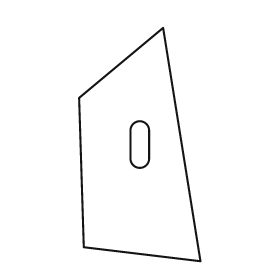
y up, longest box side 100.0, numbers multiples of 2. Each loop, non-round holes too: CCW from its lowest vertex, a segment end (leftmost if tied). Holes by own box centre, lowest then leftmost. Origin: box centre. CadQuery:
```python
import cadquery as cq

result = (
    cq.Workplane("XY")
    .moveTo(26.0, -50.0)
    .lineTo(10.0, 50.0)
    .lineTo(-26.0, 20.0)
    .lineTo(-24.0, -44.0)
    .close()
    .moveTo(-4.0, -6.0)
    .threePointArc((0.0, -10.0), (4.0, -6.0))
    .lineTo(4.0, 6.0)
    .threePointArc((0.0, 10.0), (-4.0, 6.0))
    .close()
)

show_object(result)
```